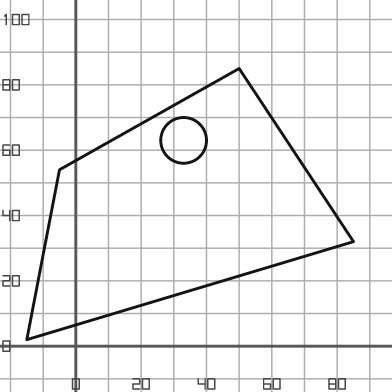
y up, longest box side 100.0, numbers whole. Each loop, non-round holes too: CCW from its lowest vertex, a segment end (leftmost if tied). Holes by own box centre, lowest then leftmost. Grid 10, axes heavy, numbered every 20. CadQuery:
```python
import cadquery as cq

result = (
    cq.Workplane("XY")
    .moveTo(-15.0, 2.0)
    .lineTo(85.0, 32.0)
    .lineTo(50.0, 85.0)
    .lineTo(-5.0, 54.0)
    .close()
    .moveTo(33.0, 63.0)
    .circle(7.0)
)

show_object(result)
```